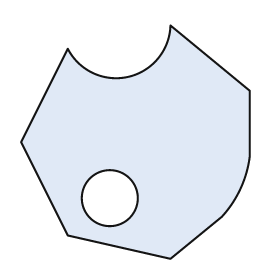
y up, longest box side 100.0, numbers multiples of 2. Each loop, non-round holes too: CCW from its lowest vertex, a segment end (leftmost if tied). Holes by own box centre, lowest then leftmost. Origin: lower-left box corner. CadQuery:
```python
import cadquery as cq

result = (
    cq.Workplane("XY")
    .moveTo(64.0, 0.0)
    .lineTo(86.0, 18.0)
    .threePointArc((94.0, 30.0), (98.0, 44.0))
    .lineTo(98.0, 72.0)
    .lineTo(64.0, 100.0)
    .threePointArc((46.0, 78.0), (20.0, 90.0))
    .lineTo(0.0, 50.0)
    .lineTo(20.0, 10.0)
    .close()
    .moveTo(38.0, 26.0)
    .circle(12.0)
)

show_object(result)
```